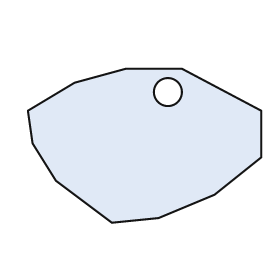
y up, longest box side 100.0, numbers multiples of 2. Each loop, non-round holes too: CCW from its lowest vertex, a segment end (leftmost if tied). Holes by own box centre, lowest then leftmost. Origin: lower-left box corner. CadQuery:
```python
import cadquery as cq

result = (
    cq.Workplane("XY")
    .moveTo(36.0, 0.0)
    .lineTo(56.0, 2.0)
    .lineTo(80.0, 12.0)
    .lineTo(100.0, 28.0)
    .lineTo(100.0, 48.0)
    .lineTo(66.0, 66.0)
    .lineTo(42.0, 66.0)
    .lineTo(20.0, 60.0)
    .lineTo(0.0, 48.0)
    .lineTo(2.0, 34.0)
    .lineTo(12.0, 18.0)
    .close()
    .moveTo(60.0, 56.0)
    .circle(6.0)
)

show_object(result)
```